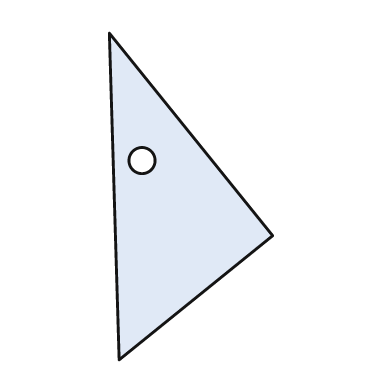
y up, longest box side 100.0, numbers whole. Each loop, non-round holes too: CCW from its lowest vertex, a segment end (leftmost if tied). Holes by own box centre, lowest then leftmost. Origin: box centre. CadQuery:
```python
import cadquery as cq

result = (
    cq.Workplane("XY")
    .moveTo(-22.0, -50.0)
    .lineTo(25.0, -12.0)
    .lineTo(-25.0, 50.0)
    .close()
    .moveTo(-15.0, 11.0)
    .circle(4.0)
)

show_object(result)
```